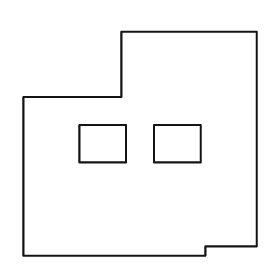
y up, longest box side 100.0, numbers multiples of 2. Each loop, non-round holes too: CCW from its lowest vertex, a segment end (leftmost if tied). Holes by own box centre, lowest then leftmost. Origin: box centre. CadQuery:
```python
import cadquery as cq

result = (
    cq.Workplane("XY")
    .moveTo(-50.0, -48.0)
    .lineTo(28.0, -48.0)
    .lineTo(28.0, -44.0)
    .lineTo(50.0, -44.0)
    .lineTo(50.0, 48.0)
    .lineTo(-8.0, 48.0)
    .lineTo(-8.0, 20.0)
    .lineTo(-50.0, 20.0)
    .close()
    .moveTo(-26.0, -8.0)
    .lineTo(-6.0, -8.0)
    .lineTo(-6.0, 8.0)
    .lineTo(-26.0, 8.0)
    .close()
    .moveTo(6.0, -8.0)
    .lineTo(26.0, -8.0)
    .lineTo(26.0, 8.0)
    .lineTo(6.0, 8.0)
    .close()
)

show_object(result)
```